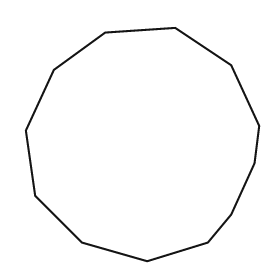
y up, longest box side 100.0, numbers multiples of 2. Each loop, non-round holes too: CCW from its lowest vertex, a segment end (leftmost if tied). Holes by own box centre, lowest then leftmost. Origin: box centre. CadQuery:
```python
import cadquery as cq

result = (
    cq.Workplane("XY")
    .moveTo(2.0, -50.0)
    .lineTo(28.0, -42.0)
    .lineTo(38.0, -30.0)
    .lineTo(48.0, -8.0)
    .lineTo(50.0, 8.0)
    .lineTo(38.0, 34.0)
    .lineTo(14.0, 50.0)
    .lineTo(-16.0, 48.0)
    .lineTo(-38.0, 32.0)
    .lineTo(-50.0, 6.0)
    .lineTo(-46.0, -22.0)
    .lineTo(-26.0, -42.0)
    .close()
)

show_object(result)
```